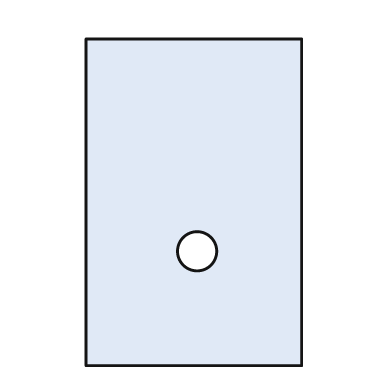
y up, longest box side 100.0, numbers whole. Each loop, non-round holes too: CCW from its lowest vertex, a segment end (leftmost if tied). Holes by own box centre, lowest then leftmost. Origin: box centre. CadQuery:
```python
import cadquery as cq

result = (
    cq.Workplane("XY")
    .moveTo(-33.0, -50.0)
    .lineTo(33.0, -50.0)
    .lineTo(33.0, 50.0)
    .lineTo(-33.0, 50.0)
    .close()
    .moveTo(1.0, -15.0)
    .circle(6.0)
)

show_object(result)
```